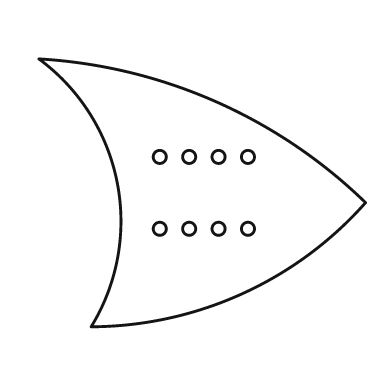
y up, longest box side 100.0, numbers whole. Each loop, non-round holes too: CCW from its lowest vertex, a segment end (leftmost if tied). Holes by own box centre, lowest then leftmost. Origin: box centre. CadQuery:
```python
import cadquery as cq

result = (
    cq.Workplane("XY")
    .moveTo(-34.0, -41.0)
    .threePointArc((12.0, -31.0), (50.0, -3.0))
    .threePointArc((4.0, 28.0), (-50.0, 41.0))
    .threePointArc((-26.0, 3.0), (-34.0, -41.0))
    .close()
    .moveTo(-13.0, -11.0)
    .circle(2.0)
    .moveTo(-4.0, -11.0)
    .circle(2.0)
    .moveTo(5.0, -11.0)
    .circle(2.0)
    .moveTo(14.0, -11.0)
    .circle(2.0)
    .moveTo(-13.0, 11.0)
    .circle(2.0)
    .moveTo(-4.0, 11.0)
    .circle(2.0)
    .moveTo(5.0, 11.0)
    .circle(2.0)
    .moveTo(14.0, 11.0)
    .circle(2.0)
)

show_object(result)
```